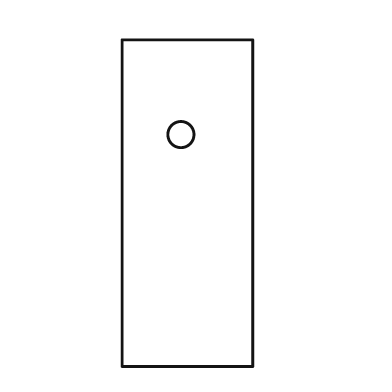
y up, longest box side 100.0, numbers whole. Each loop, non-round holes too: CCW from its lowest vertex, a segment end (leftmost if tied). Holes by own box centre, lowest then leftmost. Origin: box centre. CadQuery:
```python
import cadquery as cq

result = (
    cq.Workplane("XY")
    .moveTo(-20.0, -50.0)
    .lineTo(20.0, -50.0)
    .lineTo(20.0, 50.0)
    .lineTo(-20.0, 50.0)
    .close()
    .moveTo(-2.0, 21.0)
    .circle(4.0)
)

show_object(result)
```